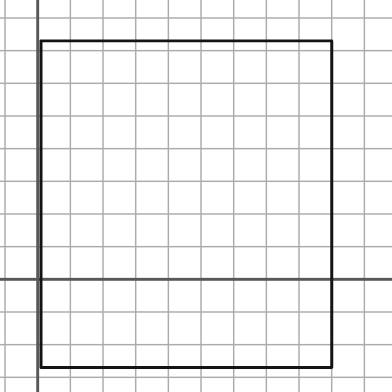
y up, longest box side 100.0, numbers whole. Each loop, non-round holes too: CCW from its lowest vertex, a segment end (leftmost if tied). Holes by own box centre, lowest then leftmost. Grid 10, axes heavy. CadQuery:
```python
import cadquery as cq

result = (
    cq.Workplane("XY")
    .moveTo(1.0, -27.0)
    .lineTo(90.0, -27.0)
    .lineTo(90.0, 73.0)
    .lineTo(1.0, 73.0)
    .close()
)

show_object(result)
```